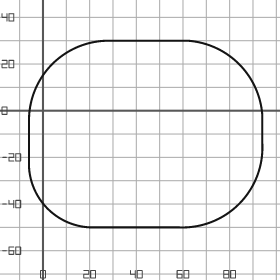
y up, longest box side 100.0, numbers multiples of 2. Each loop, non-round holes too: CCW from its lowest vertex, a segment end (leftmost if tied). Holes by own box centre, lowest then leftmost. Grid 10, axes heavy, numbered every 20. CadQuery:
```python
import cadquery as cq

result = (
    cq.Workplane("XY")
    .moveTo(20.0, -50.0)
    .lineTo(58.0, -50.0)
    .threePointArc((84.0, -40.0), (94.0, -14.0))
    .lineTo(94.0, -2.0)
    .threePointArc((84.0, 20.0), (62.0, 30.0))
    .lineTo(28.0, 30.0)
    .threePointArc((4.0, 20.0), (-6.0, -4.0))
    .lineTo(-6.0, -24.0)
    .threePointArc((2.0, -42.0), (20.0, -50.0))
    .close()
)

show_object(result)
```